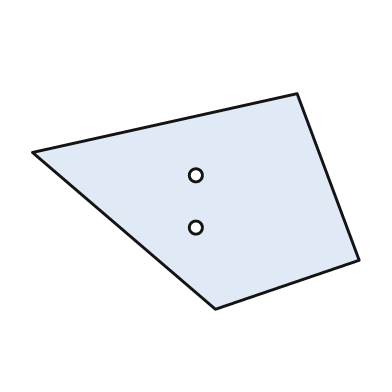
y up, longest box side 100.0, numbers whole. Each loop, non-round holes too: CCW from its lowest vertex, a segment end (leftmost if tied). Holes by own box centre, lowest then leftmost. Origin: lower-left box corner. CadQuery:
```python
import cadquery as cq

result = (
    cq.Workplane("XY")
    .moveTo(56.0, 0.0)
    .lineTo(100.0, 15.0)
    .lineTo(81.0, 66.0)
    .lineTo(0.0, 48.0)
    .close()
    .moveTo(50.0, 25.0)
    .circle(2.0)
    .moveTo(50.0, 41.0)
    .circle(2.0)
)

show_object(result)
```